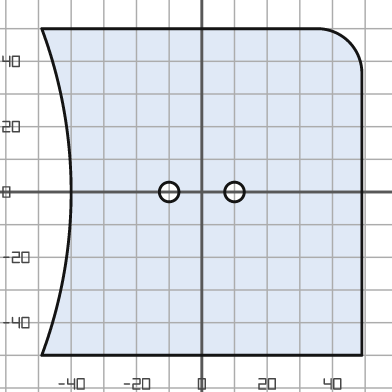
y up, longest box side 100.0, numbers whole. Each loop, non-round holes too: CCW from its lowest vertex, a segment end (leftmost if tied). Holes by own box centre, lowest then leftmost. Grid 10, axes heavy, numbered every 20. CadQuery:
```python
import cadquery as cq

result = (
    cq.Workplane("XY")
    .moveTo(-49.0, -50.0)
    .lineTo(49.0, -50.0)
    .lineTo(49.0, 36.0)
    .threePointArc((45.0, 46.0), (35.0, 50.0))
    .lineTo(-49.0, 50.0)
    .threePointArc((-40.0, 0.0), (-49.0, -50.0))
    .close()
    .moveTo(-10.0, 0.0)
    .circle(3.0)
    .moveTo(10.0, 0.0)
    .circle(3.0)
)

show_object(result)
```